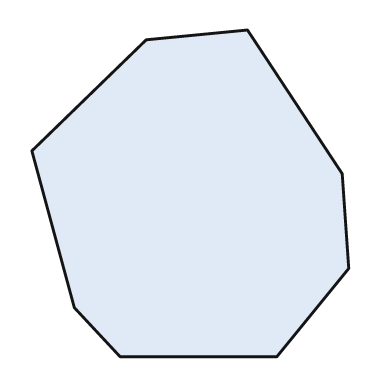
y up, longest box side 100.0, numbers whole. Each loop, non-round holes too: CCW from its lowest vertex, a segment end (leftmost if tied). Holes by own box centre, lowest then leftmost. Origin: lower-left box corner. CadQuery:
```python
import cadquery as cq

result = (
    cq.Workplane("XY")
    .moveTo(27.0, 0.0)
    .lineTo(75.0, 0.0)
    .lineTo(97.0, 27.0)
    .lineTo(95.0, 56.0)
    .lineTo(66.0, 100.0)
    .lineTo(35.0, 97.0)
    .lineTo(0.0, 63.0)
    .lineTo(13.0, 15.0)
    .close()
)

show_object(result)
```